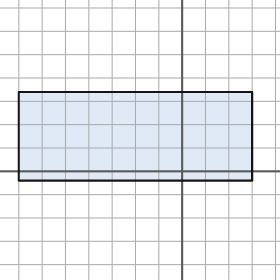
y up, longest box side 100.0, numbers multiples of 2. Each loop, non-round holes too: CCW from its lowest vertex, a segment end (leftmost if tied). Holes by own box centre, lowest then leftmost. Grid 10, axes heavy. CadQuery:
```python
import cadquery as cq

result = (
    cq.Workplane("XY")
    .moveTo(-70.0, -4.0)
    .lineTo(30.0, -4.0)
    .lineTo(30.0, 34.0)
    .lineTo(-70.0, 34.0)
    .close()
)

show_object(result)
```